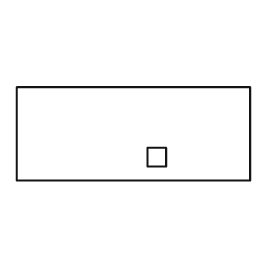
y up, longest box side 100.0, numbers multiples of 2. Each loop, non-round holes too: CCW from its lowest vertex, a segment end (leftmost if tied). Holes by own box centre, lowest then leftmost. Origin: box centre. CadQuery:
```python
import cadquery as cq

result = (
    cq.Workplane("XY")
    .moveTo(-50.0, -20.0)
    .lineTo(50.0, -20.0)
    .lineTo(50.0, 20.0)
    .lineTo(-50.0, 20.0)
    .close()
    .moveTo(6.0, -14.0)
    .lineTo(14.0, -14.0)
    .lineTo(14.0, -6.0)
    .lineTo(6.0, -6.0)
    .close()
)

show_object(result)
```